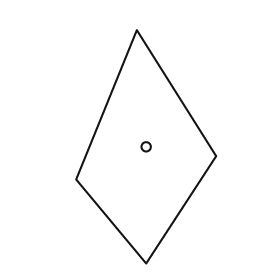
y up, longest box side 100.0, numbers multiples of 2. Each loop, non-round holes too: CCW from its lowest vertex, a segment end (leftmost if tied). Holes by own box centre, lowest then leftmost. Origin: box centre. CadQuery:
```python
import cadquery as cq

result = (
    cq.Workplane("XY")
    .moveTo(0.0, -50.0)
    .lineTo(30.0, -4.0)
    .lineTo(-4.0, 50.0)
    .lineTo(-30.0, -14.0)
    .close()
    .moveTo(0.0, 0.0)
    .circle(2.0)
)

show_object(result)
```